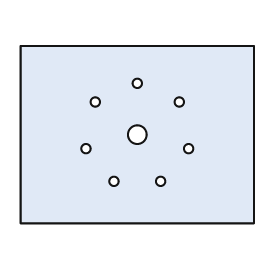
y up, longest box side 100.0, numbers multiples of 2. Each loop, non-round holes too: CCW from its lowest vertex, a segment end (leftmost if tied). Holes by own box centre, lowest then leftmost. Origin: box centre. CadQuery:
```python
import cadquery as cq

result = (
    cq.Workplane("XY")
    .moveTo(-50.0, -38.0)
    .lineTo(50.0, -38.0)
    .lineTo(50.0, 38.0)
    .lineTo(-50.0, 38.0)
    .close()
    .moveTo(-10.0, -20.0)
    .circle(2.0)
    .moveTo(10.0, -20.0)
    .circle(2.0)
    .moveTo(-22.0, -6.0)
    .circle(2.0)
    .moveTo(22.0, -6.0)
    .circle(2.0)
    .moveTo(0.0, 0.0)
    .circle(4.0)
    .moveTo(-18.0, 14.0)
    .circle(2.0)
    .moveTo(18.0, 14.0)
    .circle(2.0)
    .moveTo(0.0, 22.0)
    .circle(2.0)
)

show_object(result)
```